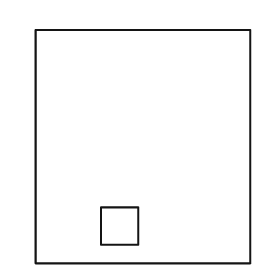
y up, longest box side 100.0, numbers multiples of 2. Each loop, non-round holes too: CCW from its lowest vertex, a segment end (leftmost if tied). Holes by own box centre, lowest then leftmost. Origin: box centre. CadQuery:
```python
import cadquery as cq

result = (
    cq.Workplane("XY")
    .moveTo(-46.0, -50.0)
    .lineTo(46.0, -50.0)
    .lineTo(46.0, 50.0)
    .lineTo(-46.0, 50.0)
    .close()
    .moveTo(-18.0, -42.0)
    .lineTo(-2.0, -42.0)
    .lineTo(-2.0, -26.0)
    .lineTo(-18.0, -26.0)
    .close()
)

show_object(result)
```